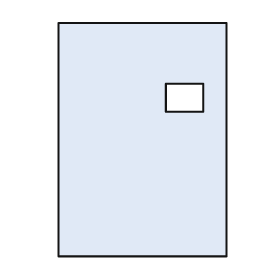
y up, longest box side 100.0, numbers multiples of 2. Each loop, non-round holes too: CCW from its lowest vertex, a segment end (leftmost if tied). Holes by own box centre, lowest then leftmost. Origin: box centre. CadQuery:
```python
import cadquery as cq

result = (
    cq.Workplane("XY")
    .moveTo(-36.0, -50.0)
    .lineTo(36.0, -50.0)
    .lineTo(36.0, 50.0)
    .lineTo(-36.0, 50.0)
    .close()
    .moveTo(10.0, 12.0)
    .lineTo(26.0, 12.0)
    .lineTo(26.0, 24.0)
    .lineTo(10.0, 24.0)
    .close()
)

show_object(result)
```